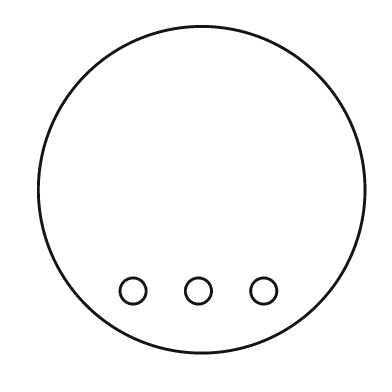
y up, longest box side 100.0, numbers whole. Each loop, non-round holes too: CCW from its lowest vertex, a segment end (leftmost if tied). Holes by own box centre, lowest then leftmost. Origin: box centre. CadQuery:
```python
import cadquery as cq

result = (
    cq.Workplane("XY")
    .moveTo(0.0, 0.0)
    .circle(50.0)
    .moveTo(-21.0, -31.0)
    .circle(4.0)
    .moveTo(-1.0, -31.0)
    .circle(4.0)
    .moveTo(19.0, -31.0)
    .circle(4.0)
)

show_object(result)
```